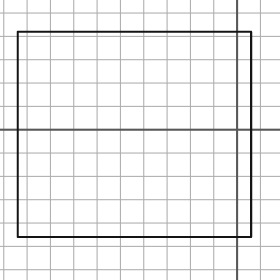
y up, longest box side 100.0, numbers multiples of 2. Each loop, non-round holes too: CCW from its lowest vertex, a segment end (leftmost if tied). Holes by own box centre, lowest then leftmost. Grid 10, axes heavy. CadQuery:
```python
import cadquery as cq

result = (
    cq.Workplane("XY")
    .moveTo(-94.0, -46.0)
    .lineTo(6.0, -46.0)
    .lineTo(6.0, 42.0)
    .lineTo(-94.0, 42.0)
    .close()
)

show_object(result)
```